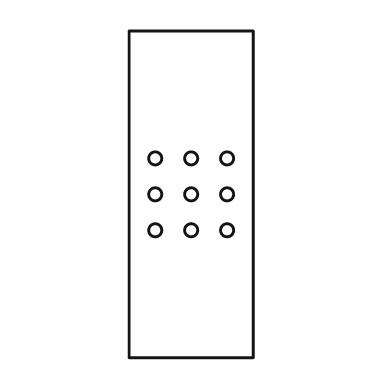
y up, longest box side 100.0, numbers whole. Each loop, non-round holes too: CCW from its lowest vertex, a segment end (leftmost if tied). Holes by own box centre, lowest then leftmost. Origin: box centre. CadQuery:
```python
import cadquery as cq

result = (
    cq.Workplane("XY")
    .moveTo(-19.0, -50.0)
    .lineTo(19.0, -50.0)
    .lineTo(19.0, 50.0)
    .lineTo(-19.0, 50.0)
    .close()
    .moveTo(-11.0, -11.0)
    .circle(2.0)
    .moveTo(0.0, -11.0)
    .circle(2.0)
    .moveTo(11.0, -11.0)
    .circle(2.0)
    .moveTo(-11.0, 0.0)
    .circle(2.0)
    .moveTo(0.0, 0.0)
    .circle(2.0)
    .moveTo(11.0, 0.0)
    .circle(2.0)
    .moveTo(-11.0, 11.0)
    .circle(2.0)
    .moveTo(0.0, 11.0)
    .circle(2.0)
    .moveTo(11.0, 11.0)
    .circle(2.0)
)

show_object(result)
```